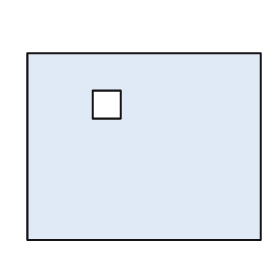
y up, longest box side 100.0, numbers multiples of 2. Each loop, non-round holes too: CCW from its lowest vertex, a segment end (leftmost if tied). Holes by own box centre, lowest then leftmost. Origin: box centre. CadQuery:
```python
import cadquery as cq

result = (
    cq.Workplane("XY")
    .moveTo(-50.0, -40.0)
    .lineTo(50.0, -40.0)
    .lineTo(50.0, 40.0)
    .lineTo(-50.0, 40.0)
    .close()
    .moveTo(-22.0, 12.0)
    .lineTo(-10.0, 12.0)
    .lineTo(-10.0, 24.0)
    .lineTo(-22.0, 24.0)
    .close()
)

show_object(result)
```